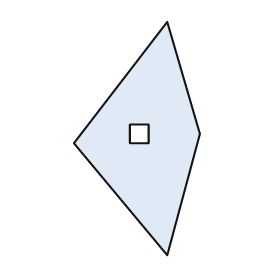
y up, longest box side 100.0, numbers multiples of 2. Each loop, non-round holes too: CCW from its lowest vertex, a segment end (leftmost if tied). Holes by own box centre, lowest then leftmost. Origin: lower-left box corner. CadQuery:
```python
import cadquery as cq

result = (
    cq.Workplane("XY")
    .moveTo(40.0, 0.0)
    .lineTo(54.0, 52.0)
    .lineTo(40.0, 100.0)
    .lineTo(0.0, 48.0)
    .close()
    .moveTo(24.0, 48.0)
    .lineTo(32.0, 48.0)
    .lineTo(32.0, 56.0)
    .lineTo(24.0, 56.0)
    .close()
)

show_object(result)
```